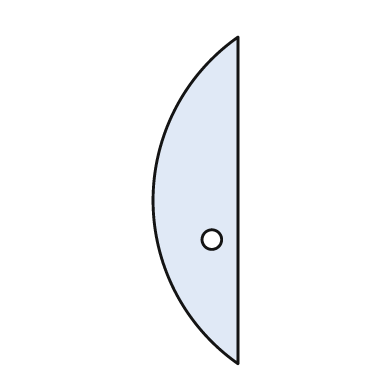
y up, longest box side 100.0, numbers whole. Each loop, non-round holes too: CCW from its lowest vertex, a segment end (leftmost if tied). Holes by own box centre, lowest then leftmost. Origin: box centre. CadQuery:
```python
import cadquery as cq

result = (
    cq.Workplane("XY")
    .moveTo(13.0, -50.0)
    .lineTo(13.0, 50.0)
    .threePointArc((-13.0, 0.0), (13.0, -50.0))
    .close()
    .moveTo(5.0, -12.0)
    .circle(3.0)
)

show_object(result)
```